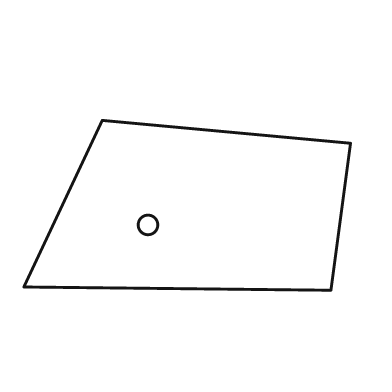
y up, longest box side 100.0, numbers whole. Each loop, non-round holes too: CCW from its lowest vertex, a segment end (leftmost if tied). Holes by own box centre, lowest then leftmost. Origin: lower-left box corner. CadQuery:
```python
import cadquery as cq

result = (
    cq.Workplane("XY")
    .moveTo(94.0, 0.0)
    .lineTo(100.0, 45.0)
    .lineTo(24.0, 52.0)
    .lineTo(0.0, 1.0)
    .close()
    .moveTo(38.0, 20.0)
    .circle(3.0)
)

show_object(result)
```